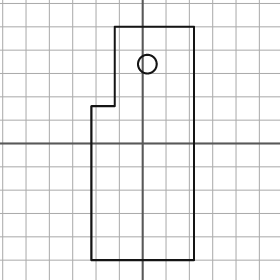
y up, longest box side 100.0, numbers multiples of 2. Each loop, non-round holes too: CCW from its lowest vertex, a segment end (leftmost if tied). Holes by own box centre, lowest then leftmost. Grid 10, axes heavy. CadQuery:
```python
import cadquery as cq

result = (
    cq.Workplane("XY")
    .moveTo(-22.0, -50.0)
    .lineTo(22.0, -50.0)
    .lineTo(22.0, 50.0)
    .lineTo(-12.0, 50.0)
    .lineTo(-12.0, 16.0)
    .lineTo(-22.0, 16.0)
    .close()
    .moveTo(2.0, 34.0)
    .circle(4.0)
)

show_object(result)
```